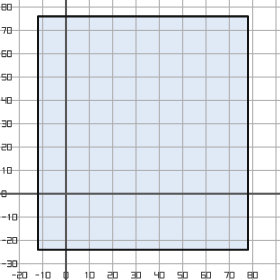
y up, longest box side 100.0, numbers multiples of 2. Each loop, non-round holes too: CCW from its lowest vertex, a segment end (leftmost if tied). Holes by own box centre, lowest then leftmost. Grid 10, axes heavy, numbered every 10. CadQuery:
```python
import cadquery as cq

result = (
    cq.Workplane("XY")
    .moveTo(-12.0, -24.0)
    .lineTo(78.0, -24.0)
    .lineTo(78.0, 76.0)
    .lineTo(-12.0, 76.0)
    .close()
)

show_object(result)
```